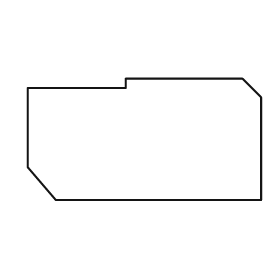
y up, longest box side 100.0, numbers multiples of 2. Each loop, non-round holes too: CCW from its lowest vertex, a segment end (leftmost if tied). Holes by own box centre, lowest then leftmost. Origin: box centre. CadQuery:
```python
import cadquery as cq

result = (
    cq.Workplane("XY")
    .moveTo(-38.0, -26.0)
    .lineTo(50.0, -26.0)
    .lineTo(50.0, 18.0)
    .lineTo(42.0, 26.0)
    .lineTo(-8.0, 26.0)
    .lineTo(-8.0, 22.0)
    .lineTo(-50.0, 22.0)
    .lineTo(-50.0, -12.0)
    .close()
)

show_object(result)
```